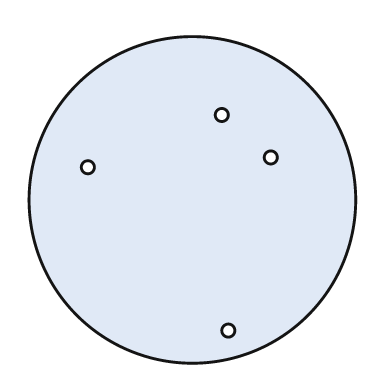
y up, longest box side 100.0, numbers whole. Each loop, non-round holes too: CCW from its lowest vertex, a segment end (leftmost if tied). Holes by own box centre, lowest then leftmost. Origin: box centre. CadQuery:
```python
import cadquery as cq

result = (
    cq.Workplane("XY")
    .moveTo(0.0, 0.0)
    .circle(50.0)
    .moveTo(11.0, -40.0)
    .circle(2.0)
    .moveTo(-32.0, 10.0)
    .circle(2.0)
    .moveTo(24.0, 13.0)
    .circle(2.0)
    .moveTo(9.0, 26.0)
    .circle(2.0)
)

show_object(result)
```